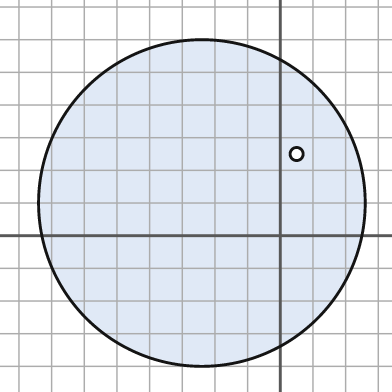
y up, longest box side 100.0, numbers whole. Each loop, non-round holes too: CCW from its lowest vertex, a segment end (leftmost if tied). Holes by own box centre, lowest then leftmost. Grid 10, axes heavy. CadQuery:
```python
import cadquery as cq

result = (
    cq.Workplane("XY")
    .moveTo(-24.0, 10.0)
    .circle(50.0)
    .moveTo(5.0, 25.0)
    .circle(2.0)
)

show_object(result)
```